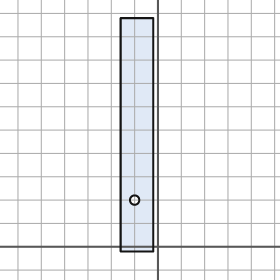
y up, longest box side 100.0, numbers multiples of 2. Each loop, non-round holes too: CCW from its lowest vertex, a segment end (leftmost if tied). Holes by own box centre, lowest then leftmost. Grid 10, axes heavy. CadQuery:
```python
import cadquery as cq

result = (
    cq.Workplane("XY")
    .moveTo(-16.0, -2.0)
    .lineTo(-2.0, -2.0)
    .lineTo(-2.0, 98.0)
    .lineTo(-16.0, 98.0)
    .close()
    .moveTo(-10.0, 20.0)
    .circle(2.0)
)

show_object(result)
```